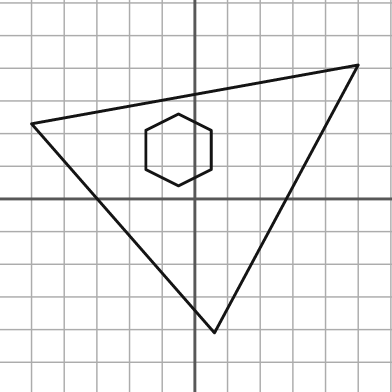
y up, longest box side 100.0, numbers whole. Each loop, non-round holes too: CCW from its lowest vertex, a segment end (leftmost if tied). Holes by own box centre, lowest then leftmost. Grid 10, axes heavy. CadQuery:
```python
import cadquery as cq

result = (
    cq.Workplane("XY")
    .moveTo(6.0, -41.0)
    .lineTo(50.0, 41.0)
    .lineTo(-50.0, 23.0)
    .close()
    .moveTo(-5.0, 4.0)
    .lineTo(5.0, 9.0)
    .lineTo(5.0, 21.0)
    .lineTo(-5.0, 26.0)
    .lineTo(-15.0, 21.0)
    .lineTo(-15.0, 9.0)
    .close()
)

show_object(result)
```